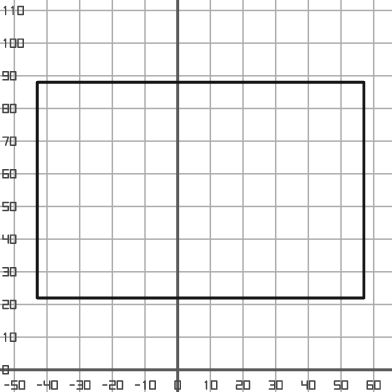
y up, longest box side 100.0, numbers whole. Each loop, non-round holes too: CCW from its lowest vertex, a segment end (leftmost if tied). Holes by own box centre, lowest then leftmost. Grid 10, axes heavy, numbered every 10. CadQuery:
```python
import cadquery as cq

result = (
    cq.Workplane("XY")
    .moveTo(-43.0, 22.0)
    .lineTo(57.0, 22.0)
    .lineTo(57.0, 88.0)
    .lineTo(-43.0, 88.0)
    .close()
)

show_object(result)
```